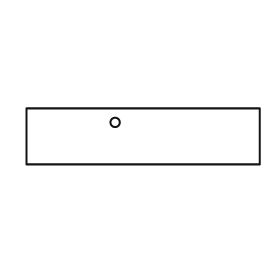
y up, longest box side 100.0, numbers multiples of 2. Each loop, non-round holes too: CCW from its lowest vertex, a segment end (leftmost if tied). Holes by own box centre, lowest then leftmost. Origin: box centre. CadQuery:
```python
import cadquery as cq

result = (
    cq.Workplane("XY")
    .moveTo(-50.0, -12.0)
    .lineTo(50.0, -12.0)
    .lineTo(50.0, 12.0)
    .lineTo(-50.0, 12.0)
    .close()
    .moveTo(-12.0, 6.0)
    .circle(2.0)
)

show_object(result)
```